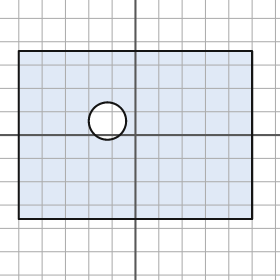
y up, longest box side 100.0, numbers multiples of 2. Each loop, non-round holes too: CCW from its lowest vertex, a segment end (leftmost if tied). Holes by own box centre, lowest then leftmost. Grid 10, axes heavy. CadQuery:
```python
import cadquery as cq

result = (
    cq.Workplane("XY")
    .moveTo(-50.0, -36.0)
    .lineTo(50.0, -36.0)
    .lineTo(50.0, 36.0)
    .lineTo(-50.0, 36.0)
    .close()
    .moveTo(-12.0, 6.0)
    .circle(8.0)
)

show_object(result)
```